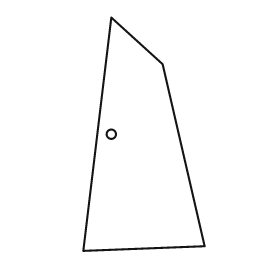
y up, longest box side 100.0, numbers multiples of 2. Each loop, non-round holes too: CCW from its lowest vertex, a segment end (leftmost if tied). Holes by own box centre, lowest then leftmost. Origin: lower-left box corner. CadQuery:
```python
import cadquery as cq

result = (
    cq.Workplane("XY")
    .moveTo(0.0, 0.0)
    .lineTo(52.0, 2.0)
    .lineTo(34.0, 80.0)
    .lineTo(12.0, 100.0)
    .close()
    .moveTo(12.0, 50.0)
    .circle(2.0)
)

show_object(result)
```